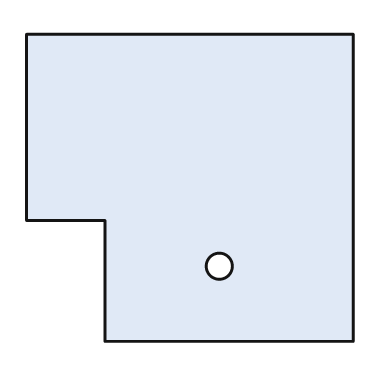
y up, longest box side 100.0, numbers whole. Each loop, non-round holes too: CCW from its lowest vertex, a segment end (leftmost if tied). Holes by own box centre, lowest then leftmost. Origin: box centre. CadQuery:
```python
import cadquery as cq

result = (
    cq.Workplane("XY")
    .moveTo(-26.0, -47.0)
    .lineTo(50.0, -47.0)
    .lineTo(50.0, 47.0)
    .lineTo(-50.0, 47.0)
    .lineTo(-50.0, -10.0)
    .lineTo(-26.0, -10.0)
    .close()
    .moveTo(9.0, -24.0)
    .circle(4.0)
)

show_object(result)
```